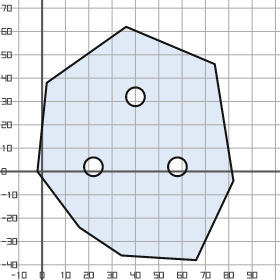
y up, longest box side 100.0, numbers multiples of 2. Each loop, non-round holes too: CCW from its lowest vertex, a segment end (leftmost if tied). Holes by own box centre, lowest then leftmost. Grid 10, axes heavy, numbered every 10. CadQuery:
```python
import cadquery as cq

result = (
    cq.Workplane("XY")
    .moveTo(66.0, -38.0)
    .lineTo(82.0, -4.0)
    .lineTo(74.0, 46.0)
    .lineTo(36.0, 62.0)
    .lineTo(2.0, 38.0)
    .lineTo(-2.0, 0.0)
    .lineTo(16.0, -24.0)
    .lineTo(34.0, -36.0)
    .close()
    .moveTo(22.0, 2.0)
    .circle(4.0)
    .moveTo(58.0, 2.0)
    .circle(4.0)
    .moveTo(40.0, 32.0)
    .circle(4.0)
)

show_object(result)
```